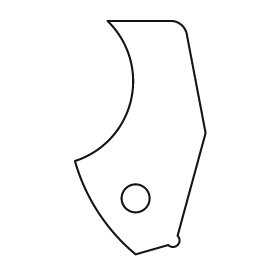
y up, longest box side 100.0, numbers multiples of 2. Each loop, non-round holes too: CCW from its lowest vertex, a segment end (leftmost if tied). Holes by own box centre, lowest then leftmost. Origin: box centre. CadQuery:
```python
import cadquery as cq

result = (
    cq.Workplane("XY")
    .moveTo(-2.0, -50.0)
    .lineTo(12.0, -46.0)
    .threePointArc((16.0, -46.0), (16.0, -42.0))
    .lineTo(28.0, 2.0)
    .lineTo(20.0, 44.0)
    .threePointArc((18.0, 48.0), (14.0, 50.0))
    .lineTo(-14.0, 50.0)
    .threePointArc((-4.0, 16.0), (-28.0, -10.0))
    .threePointArc((-18.0, -32.0), (-2.0, -50.0))
    .close()
    .moveTo(-2.0, -26.0)
    .circle(6.0)
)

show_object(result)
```